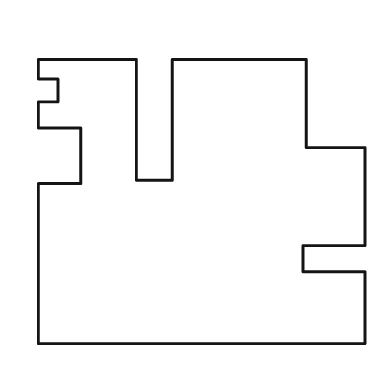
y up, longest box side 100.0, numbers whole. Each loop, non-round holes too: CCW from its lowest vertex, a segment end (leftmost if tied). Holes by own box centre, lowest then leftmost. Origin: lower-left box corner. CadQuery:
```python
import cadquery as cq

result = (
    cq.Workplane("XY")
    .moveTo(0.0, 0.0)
    .lineTo(100.0, 0.0)
    .lineTo(100.0, 22.0)
    .lineTo(81.0, 22.0)
    .lineTo(81.0, 30.0)
    .lineTo(100.0, 30.0)
    .lineTo(100.0, 60.0)
    .lineTo(82.0, 60.0)
    .lineTo(82.0, 87.0)
    .lineTo(41.0, 87.0)
    .lineTo(41.0, 50.0)
    .lineTo(30.0, 50.0)
    .lineTo(30.0, 87.0)
    .lineTo(0.0, 87.0)
    .lineTo(0.0, 81.0)
    .lineTo(6.0, 81.0)
    .lineTo(6.0, 74.0)
    .lineTo(0.0, 74.0)
    .lineTo(0.0, 66.0)
    .lineTo(13.0, 66.0)
    .lineTo(13.0, 49.0)
    .lineTo(0.0, 49.0)
    .close()
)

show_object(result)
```